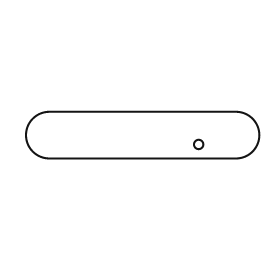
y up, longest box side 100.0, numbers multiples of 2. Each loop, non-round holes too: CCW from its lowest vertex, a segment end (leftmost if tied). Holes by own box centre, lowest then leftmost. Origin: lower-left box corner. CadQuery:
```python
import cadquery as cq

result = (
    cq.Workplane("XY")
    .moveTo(10.0, 0.0)
    .lineTo(90.0, 0.0)
    .threePointArc((100.0, 10.0), (90.0, 20.0))
    .lineTo(10.0, 20.0)
    .threePointArc((0.0, 10.0), (10.0, 0.0))
    .close()
    .moveTo(74.0, 6.0)
    .circle(2.0)
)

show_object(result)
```